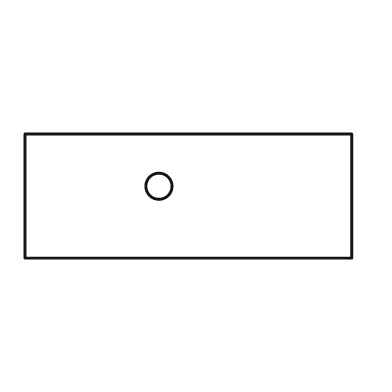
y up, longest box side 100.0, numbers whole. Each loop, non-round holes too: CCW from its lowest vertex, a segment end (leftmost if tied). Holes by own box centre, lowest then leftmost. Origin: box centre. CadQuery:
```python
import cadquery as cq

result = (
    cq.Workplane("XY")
    .moveTo(-50.0, -19.0)
    .lineTo(50.0, -19.0)
    .lineTo(50.0, 19.0)
    .lineTo(-50.0, 19.0)
    .close()
    .moveTo(-9.0, 3.0)
    .circle(4.0)
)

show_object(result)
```